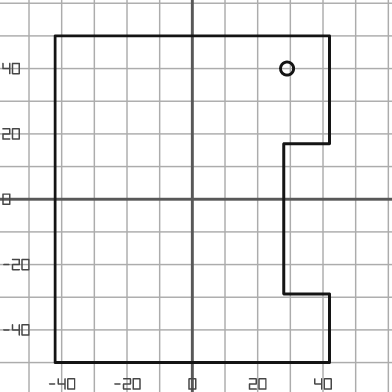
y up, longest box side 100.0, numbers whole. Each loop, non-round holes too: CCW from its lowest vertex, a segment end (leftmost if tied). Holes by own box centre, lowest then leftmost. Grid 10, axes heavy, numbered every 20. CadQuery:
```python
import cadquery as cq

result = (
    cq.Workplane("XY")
    .moveTo(-42.0, -50.0)
    .lineTo(42.0, -50.0)
    .lineTo(42.0, -29.0)
    .lineTo(28.0, -29.0)
    .lineTo(28.0, 17.0)
    .lineTo(42.0, 17.0)
    .lineTo(42.0, 50.0)
    .lineTo(-42.0, 50.0)
    .close()
    .moveTo(29.0, 40.0)
    .circle(2.0)
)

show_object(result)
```